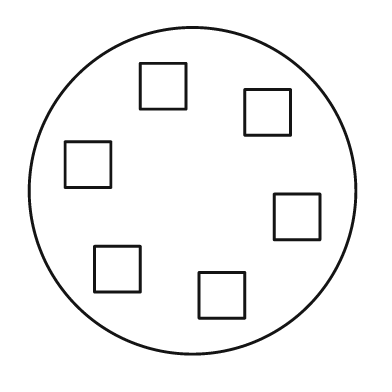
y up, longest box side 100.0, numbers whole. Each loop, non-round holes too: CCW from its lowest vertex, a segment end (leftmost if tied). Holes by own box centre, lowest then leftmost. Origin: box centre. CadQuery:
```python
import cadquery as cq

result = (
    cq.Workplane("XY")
    .moveTo(0.0, 0.0)
    .circle(50.0)
    .moveTo(2.0, -39.0)
    .lineTo(16.0, -39.0)
    .lineTo(16.0, -25.0)
    .lineTo(2.0, -25.0)
    .close()
    .moveTo(-30.0, -31.0)
    .lineTo(-16.0, -31.0)
    .lineTo(-16.0, -17.0)
    .lineTo(-30.0, -17.0)
    .close()
    .moveTo(25.0, -15.0)
    .lineTo(39.0, -15.0)
    .lineTo(39.0, -1.0)
    .lineTo(25.0, -1.0)
    .close()
    .moveTo(-39.0, 1.0)
    .lineTo(-25.0, 1.0)
    .lineTo(-25.0, 15.0)
    .lineTo(-39.0, 15.0)
    .close()
    .moveTo(16.0, 17.0)
    .lineTo(30.0, 17.0)
    .lineTo(30.0, 31.0)
    .lineTo(16.0, 31.0)
    .close()
    .moveTo(-16.0, 25.0)
    .lineTo(-2.0, 25.0)
    .lineTo(-2.0, 39.0)
    .lineTo(-16.0, 39.0)
    .close()
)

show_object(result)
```